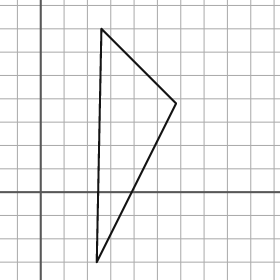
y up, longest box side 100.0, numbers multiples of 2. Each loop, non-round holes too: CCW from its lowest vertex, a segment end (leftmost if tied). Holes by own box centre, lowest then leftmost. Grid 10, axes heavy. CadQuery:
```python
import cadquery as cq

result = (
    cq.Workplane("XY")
    .moveTo(24.0, -30.0)
    .lineTo(58.0, 38.0)
    .lineTo(26.0, 70.0)
    .close()
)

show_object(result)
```